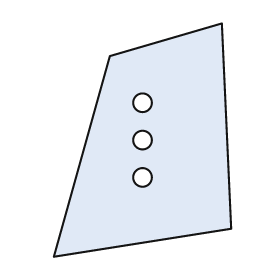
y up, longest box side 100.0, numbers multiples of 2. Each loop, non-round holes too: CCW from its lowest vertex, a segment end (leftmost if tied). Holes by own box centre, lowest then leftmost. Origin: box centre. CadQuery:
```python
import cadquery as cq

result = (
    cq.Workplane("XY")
    .moveTo(-38.0, -50.0)
    .lineTo(38.0, -38.0)
    .lineTo(34.0, 50.0)
    .lineTo(-14.0, 36.0)
    .close()
    .moveTo(0.0, -16.0)
    .circle(4.0)
    .moveTo(0.0, 0.0)
    .circle(4.0)
    .moveTo(0.0, 16.0)
    .circle(4.0)
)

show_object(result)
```